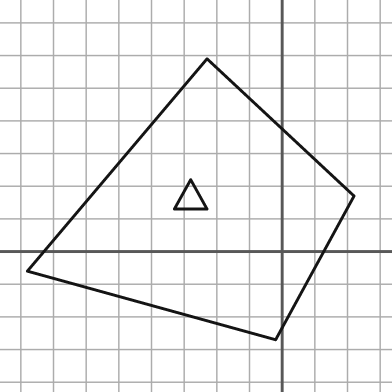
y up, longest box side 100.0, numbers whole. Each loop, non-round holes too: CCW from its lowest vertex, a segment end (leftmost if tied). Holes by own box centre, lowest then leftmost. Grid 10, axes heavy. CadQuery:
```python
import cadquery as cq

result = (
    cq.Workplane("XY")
    .moveTo(-2.0, -27.0)
    .lineTo(22.0, 17.0)
    .lineTo(-23.0, 59.0)
    .lineTo(-78.0, -6.0)
    .close()
    .moveTo(-33.0, 13.0)
    .lineTo(-23.0, 13.0)
    .lineTo(-28.0, 22.0)
    .close()
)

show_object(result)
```